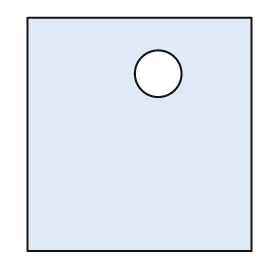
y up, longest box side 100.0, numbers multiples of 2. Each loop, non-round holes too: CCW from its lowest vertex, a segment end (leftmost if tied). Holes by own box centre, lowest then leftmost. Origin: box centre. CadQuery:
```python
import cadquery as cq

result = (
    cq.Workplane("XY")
    .moveTo(-48.0, -50.0)
    .lineTo(48.0, -50.0)
    .lineTo(48.0, 50.0)
    .lineTo(-48.0, 50.0)
    .close()
    .moveTo(8.0, 26.0)
    .circle(10.0)
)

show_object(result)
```